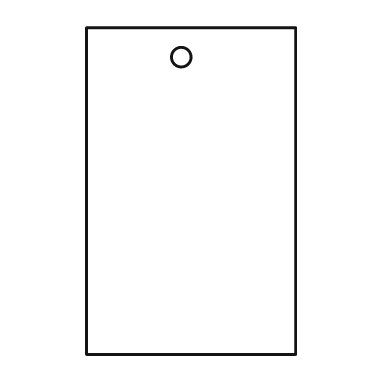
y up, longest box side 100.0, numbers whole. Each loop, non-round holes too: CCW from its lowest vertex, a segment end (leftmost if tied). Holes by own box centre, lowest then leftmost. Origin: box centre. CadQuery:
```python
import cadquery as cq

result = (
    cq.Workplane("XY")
    .moveTo(-32.0, -50.0)
    .lineTo(32.0, -50.0)
    .lineTo(32.0, 50.0)
    .lineTo(-32.0, 50.0)
    .close()
    .moveTo(-3.0, 41.0)
    .circle(3.0)
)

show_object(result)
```